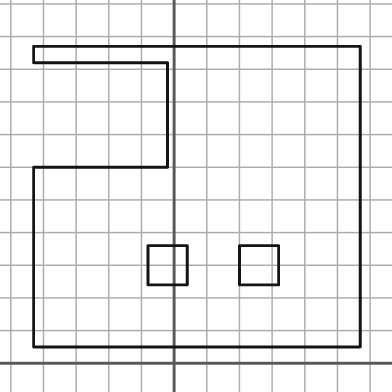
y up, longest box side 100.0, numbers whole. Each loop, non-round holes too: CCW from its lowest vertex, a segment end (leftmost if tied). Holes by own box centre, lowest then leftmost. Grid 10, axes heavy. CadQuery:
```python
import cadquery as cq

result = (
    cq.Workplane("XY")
    .moveTo(-43.0, 5.0)
    .lineTo(57.0, 5.0)
    .lineTo(57.0, 97.0)
    .lineTo(-43.0, 97.0)
    .lineTo(-43.0, 92.0)
    .lineTo(-2.0, 92.0)
    .lineTo(-2.0, 60.0)
    .lineTo(-43.0, 60.0)
    .close()
    .moveTo(-8.0, 24.0)
    .lineTo(4.0, 24.0)
    .lineTo(4.0, 36.0)
    .lineTo(-8.0, 36.0)
    .close()
    .moveTo(20.0, 24.0)
    .lineTo(32.0, 24.0)
    .lineTo(32.0, 36.0)
    .lineTo(20.0, 36.0)
    .close()
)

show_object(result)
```